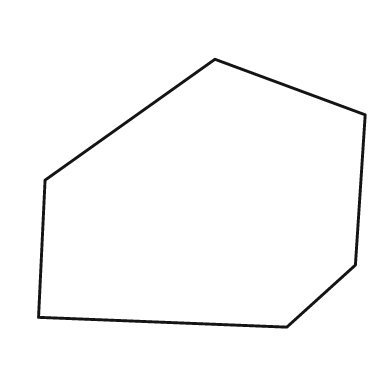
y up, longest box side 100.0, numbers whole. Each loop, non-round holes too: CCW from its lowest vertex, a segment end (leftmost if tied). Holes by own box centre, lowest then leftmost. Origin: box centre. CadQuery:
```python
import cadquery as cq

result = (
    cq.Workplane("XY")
    .moveTo(26.0, -41.0)
    .lineTo(47.0, -22.0)
    .lineTo(50.0, 24.0)
    .lineTo(4.0, 41.0)
    .lineTo(-48.0, 4.0)
    .lineTo(-50.0, -38.0)
    .close()
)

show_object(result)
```